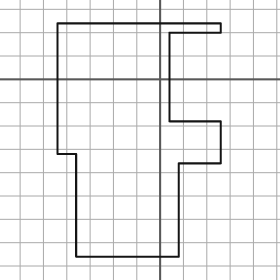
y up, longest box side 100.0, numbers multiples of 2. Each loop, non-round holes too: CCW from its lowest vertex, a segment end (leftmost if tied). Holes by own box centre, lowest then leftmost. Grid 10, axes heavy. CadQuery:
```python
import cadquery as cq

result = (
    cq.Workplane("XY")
    .moveTo(-36.0, -76.0)
    .lineTo(8.0, -76.0)
    .lineTo(8.0, -36.0)
    .lineTo(26.0, -36.0)
    .lineTo(26.0, -18.0)
    .lineTo(4.0, -18.0)
    .lineTo(4.0, 20.0)
    .lineTo(26.0, 20.0)
    .lineTo(26.0, 24.0)
    .lineTo(-44.0, 24.0)
    .lineTo(-44.0, -32.0)
    .lineTo(-36.0, -32.0)
    .close()
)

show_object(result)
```